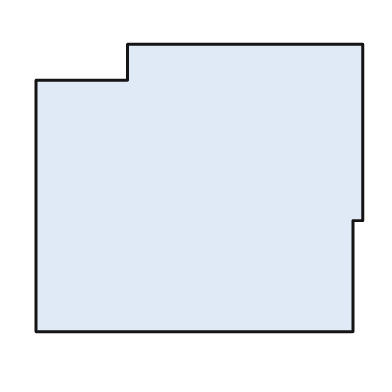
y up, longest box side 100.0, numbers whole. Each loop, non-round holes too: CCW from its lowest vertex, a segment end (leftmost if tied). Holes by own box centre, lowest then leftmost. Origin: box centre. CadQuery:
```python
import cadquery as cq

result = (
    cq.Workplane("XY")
    .moveTo(-50.0, -44.0)
    .lineTo(47.0, -44.0)
    .lineTo(47.0, -10.0)
    .lineTo(50.0, -10.0)
    .lineTo(50.0, 44.0)
    .lineTo(-22.0, 44.0)
    .lineTo(-22.0, 33.0)
    .lineTo(-50.0, 33.0)
    .close()
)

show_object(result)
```